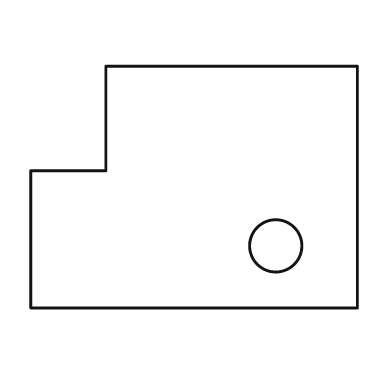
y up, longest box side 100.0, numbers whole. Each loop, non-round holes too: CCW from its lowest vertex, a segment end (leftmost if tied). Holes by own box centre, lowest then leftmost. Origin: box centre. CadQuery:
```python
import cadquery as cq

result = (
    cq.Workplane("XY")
    .moveTo(-50.0, -37.0)
    .lineTo(50.0, -37.0)
    .lineTo(50.0, 37.0)
    .lineTo(-27.0, 37.0)
    .lineTo(-27.0, 5.0)
    .lineTo(-50.0, 5.0)
    .close()
    .moveTo(25.0, -18.0)
    .circle(8.0)
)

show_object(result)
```